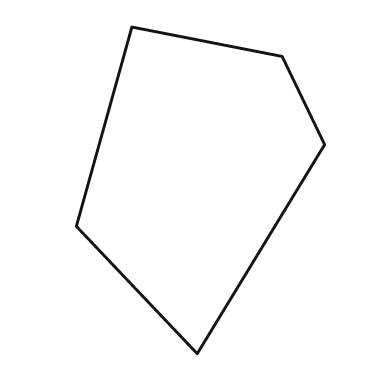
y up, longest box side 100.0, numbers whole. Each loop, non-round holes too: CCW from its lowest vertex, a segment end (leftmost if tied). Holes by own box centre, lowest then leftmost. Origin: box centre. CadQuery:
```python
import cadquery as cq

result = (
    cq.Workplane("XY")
    .moveTo(-1.0, -50.0)
    .lineTo(38.0, 14.0)
    .lineTo(25.0, 41.0)
    .lineTo(-21.0, 50.0)
    .lineTo(-38.0, -11.0)
    .close()
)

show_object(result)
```